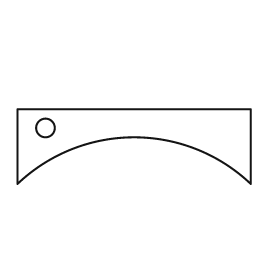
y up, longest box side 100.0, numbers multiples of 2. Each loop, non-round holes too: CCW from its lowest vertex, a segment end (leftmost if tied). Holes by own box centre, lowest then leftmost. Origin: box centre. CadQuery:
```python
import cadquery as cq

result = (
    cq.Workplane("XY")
    .moveTo(-50.0, -16.0)
    .threePointArc((0.0, 4.0), (50.0, -16.0))
    .lineTo(50.0, 16.0)
    .lineTo(-50.0, 16.0)
    .close()
    .moveTo(-38.0, 8.0)
    .circle(4.0)
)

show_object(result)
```